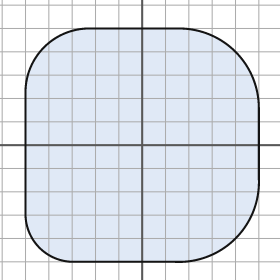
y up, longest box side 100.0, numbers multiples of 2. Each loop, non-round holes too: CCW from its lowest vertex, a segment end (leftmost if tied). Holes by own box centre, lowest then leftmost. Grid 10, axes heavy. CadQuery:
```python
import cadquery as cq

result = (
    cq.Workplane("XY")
    .moveTo(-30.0, -50.0)
    .lineTo(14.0, -50.0)
    .threePointArc((40.0, -40.0), (50.0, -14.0))
    .lineTo(50.0, 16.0)
    .threePointArc((40.0, 40.0), (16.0, 50.0))
    .lineTo(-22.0, 50.0)
    .threePointArc((-42.0, 42.0), (-50.0, 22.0))
    .lineTo(-50.0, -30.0)
    .threePointArc((-44.0, -44.0), (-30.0, -50.0))
    .close()
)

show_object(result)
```